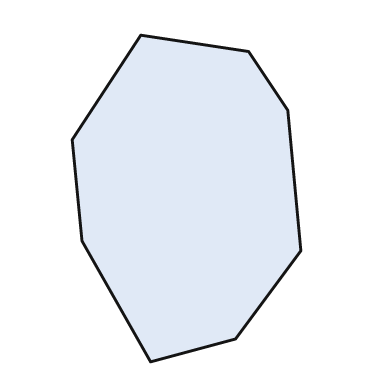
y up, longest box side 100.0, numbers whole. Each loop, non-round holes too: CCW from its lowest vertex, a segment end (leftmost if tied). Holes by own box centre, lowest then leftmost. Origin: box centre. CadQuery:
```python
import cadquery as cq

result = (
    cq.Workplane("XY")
    .moveTo(-11.0, -50.0)
    .lineTo(15.0, -43.0)
    .lineTo(35.0, -16.0)
    .lineTo(31.0, 27.0)
    .lineTo(19.0, 45.0)
    .lineTo(-14.0, 50.0)
    .lineTo(-35.0, 18.0)
    .lineTo(-32.0, -13.0)
    .close()
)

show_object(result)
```